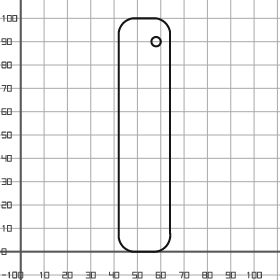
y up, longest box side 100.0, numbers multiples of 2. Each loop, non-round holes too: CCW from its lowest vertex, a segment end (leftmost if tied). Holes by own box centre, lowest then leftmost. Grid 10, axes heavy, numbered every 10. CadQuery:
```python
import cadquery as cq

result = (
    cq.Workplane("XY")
    .moveTo(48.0, 0.0)
    .lineTo(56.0, 0.0)
    .threePointArc((62.0, 2.0), (64.0, 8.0))
    .lineTo(64.0, 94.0)
    .threePointArc((62.0, 98.0), (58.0, 100.0))
    .lineTo(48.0, 100.0)
    .threePointArc((44.0, 98.0), (42.0, 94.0))
    .lineTo(42.0, 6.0)
    .threePointArc((44.0, 2.0), (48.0, 0.0))
    .close()
    .moveTo(58.0, 90.0)
    .circle(2.0)
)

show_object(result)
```